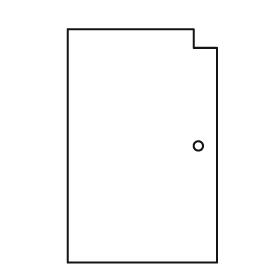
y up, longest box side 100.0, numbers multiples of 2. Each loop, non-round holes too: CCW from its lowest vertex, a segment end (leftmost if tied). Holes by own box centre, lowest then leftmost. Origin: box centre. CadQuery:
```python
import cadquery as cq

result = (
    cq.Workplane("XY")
    .moveTo(-32.0, -50.0)
    .lineTo(32.0, -50.0)
    .lineTo(32.0, 42.0)
    .lineTo(22.0, 42.0)
    .lineTo(22.0, 50.0)
    .lineTo(-32.0, 50.0)
    .close()
    .moveTo(24.0, 0.0)
    .circle(2.0)
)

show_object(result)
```